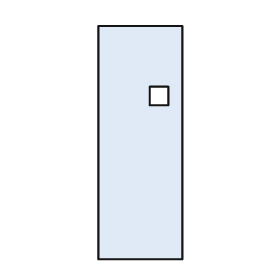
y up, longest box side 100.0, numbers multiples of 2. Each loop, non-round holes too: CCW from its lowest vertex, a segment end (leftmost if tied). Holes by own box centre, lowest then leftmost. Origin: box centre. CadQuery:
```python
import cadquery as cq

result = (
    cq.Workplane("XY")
    .moveTo(-18.0, -50.0)
    .lineTo(18.0, -50.0)
    .lineTo(18.0, 50.0)
    .lineTo(-18.0, 50.0)
    .close()
    .moveTo(4.0, 16.0)
    .lineTo(12.0, 16.0)
    .lineTo(12.0, 24.0)
    .lineTo(4.0, 24.0)
    .close()
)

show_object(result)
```